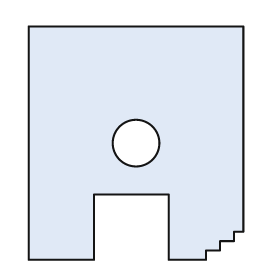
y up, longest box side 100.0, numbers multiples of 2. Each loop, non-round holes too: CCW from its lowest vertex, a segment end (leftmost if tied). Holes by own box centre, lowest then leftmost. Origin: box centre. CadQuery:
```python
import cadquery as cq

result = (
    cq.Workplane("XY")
    .moveTo(-46.0, -50.0)
    .lineTo(-18.0, -50.0)
    .lineTo(-18.0, -22.0)
    .lineTo(14.0, -22.0)
    .lineTo(14.0, -50.0)
    .lineTo(30.0, -50.0)
    .lineTo(30.0, -46.0)
    .lineTo(36.0, -46.0)
    .lineTo(36.0, -42.0)
    .lineTo(42.0, -42.0)
    .lineTo(42.0, -38.0)
    .lineTo(46.0, -38.0)
    .lineTo(46.0, 50.0)
    .lineTo(-46.0, 50.0)
    .close()
    .moveTo(0.0, 0.0)
    .circle(10.0)
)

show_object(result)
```